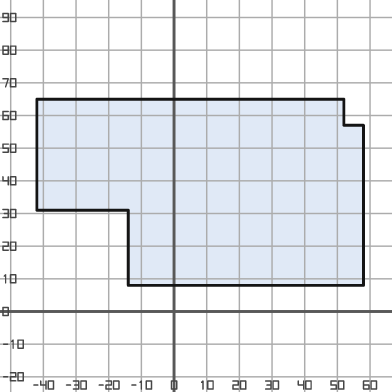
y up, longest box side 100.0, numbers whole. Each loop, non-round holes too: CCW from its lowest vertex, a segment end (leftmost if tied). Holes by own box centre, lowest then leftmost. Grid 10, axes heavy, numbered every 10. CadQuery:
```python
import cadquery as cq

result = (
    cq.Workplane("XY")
    .moveTo(-14.0, 8.0)
    .lineTo(58.0, 8.0)
    .lineTo(58.0, 57.0)
    .lineTo(52.0, 57.0)
    .lineTo(52.0, 65.0)
    .lineTo(-42.0, 65.0)
    .lineTo(-42.0, 31.0)
    .lineTo(-14.0, 31.0)
    .close()
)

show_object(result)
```